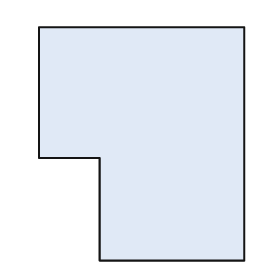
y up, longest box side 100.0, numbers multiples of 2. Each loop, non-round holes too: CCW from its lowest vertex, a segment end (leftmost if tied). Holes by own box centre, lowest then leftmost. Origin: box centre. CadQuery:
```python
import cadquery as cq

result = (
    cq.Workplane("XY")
    .moveTo(-18.0, -50.0)
    .lineTo(44.0, -50.0)
    .lineTo(44.0, 50.0)
    .lineTo(-44.0, 50.0)
    .lineTo(-44.0, -6.0)
    .lineTo(-18.0, -6.0)
    .close()
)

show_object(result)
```